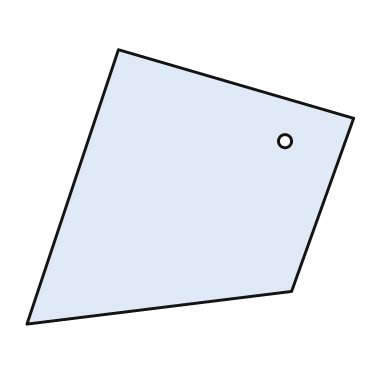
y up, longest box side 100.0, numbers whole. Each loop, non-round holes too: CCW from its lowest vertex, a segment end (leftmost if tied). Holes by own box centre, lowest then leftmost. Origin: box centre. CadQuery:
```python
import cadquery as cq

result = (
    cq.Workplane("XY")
    .moveTo(-50.0, -42.0)
    .lineTo(31.0, -32.0)
    .lineTo(50.0, 21.0)
    .lineTo(-22.0, 42.0)
    .close()
    .moveTo(29.0, 14.0)
    .circle(2.0)
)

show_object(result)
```